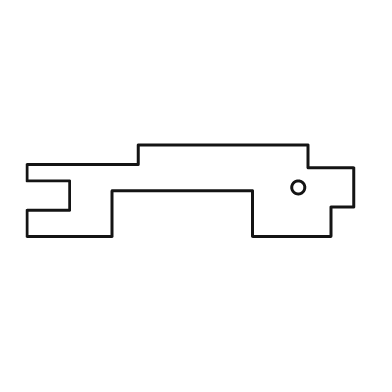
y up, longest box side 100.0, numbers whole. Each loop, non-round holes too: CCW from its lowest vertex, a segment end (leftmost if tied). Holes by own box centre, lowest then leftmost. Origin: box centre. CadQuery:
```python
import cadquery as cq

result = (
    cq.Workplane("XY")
    .moveTo(-50.0, -14.0)
    .lineTo(-24.0, -14.0)
    .lineTo(-24.0, 0.0)
    .lineTo(19.0, 0.0)
    .lineTo(19.0, -14.0)
    .lineTo(43.0, -14.0)
    .lineTo(43.0, -5.0)
    .lineTo(50.0, -5.0)
    .lineTo(50.0, 7.0)
    .lineTo(36.0, 7.0)
    .lineTo(36.0, 14.0)
    .lineTo(-16.0, 14.0)
    .lineTo(-16.0, 8.0)
    .lineTo(-50.0, 8.0)
    .lineTo(-50.0, 3.0)
    .lineTo(-37.0, 3.0)
    .lineTo(-37.0, -6.0)
    .lineTo(-50.0, -6.0)
    .close()
    .moveTo(33.0, 1.0)
    .circle(2.0)
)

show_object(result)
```